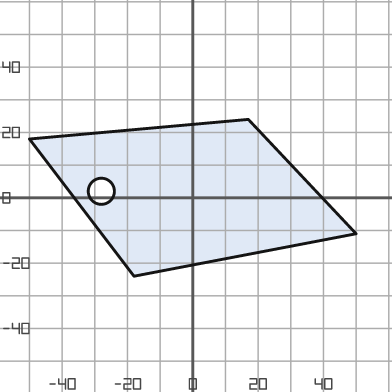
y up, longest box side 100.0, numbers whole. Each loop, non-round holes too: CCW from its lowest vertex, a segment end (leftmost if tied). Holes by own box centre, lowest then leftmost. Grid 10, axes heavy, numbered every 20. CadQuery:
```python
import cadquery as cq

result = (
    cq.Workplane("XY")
    .moveTo(-18.0, -24.0)
    .lineTo(50.0, -11.0)
    .lineTo(17.0, 24.0)
    .lineTo(-50.0, 18.0)
    .close()
    .moveTo(-28.0, 2.0)
    .circle(4.0)
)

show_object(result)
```